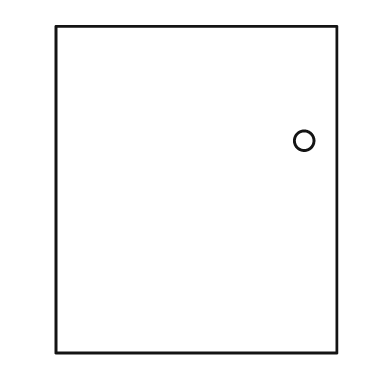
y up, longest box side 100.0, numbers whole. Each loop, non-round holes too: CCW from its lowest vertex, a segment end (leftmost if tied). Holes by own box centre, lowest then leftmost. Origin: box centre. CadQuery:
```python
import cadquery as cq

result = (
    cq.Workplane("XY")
    .moveTo(-43.0, -50.0)
    .lineTo(43.0, -50.0)
    .lineTo(43.0, 50.0)
    .lineTo(-43.0, 50.0)
    .close()
    .moveTo(33.0, 15.0)
    .circle(3.0)
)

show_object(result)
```